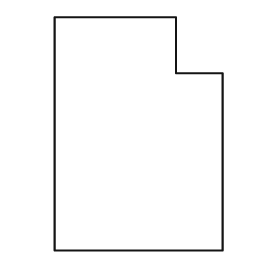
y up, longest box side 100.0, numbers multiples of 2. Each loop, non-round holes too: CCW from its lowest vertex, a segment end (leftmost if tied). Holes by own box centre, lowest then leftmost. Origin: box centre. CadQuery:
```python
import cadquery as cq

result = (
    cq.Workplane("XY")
    .moveTo(-36.0, -50.0)
    .lineTo(36.0, -50.0)
    .lineTo(36.0, 26.0)
    .lineTo(16.0, 26.0)
    .lineTo(16.0, 50.0)
    .lineTo(-36.0, 50.0)
    .close()
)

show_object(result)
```